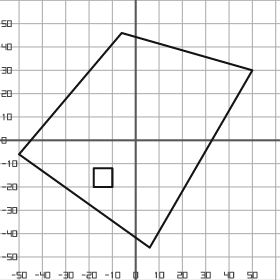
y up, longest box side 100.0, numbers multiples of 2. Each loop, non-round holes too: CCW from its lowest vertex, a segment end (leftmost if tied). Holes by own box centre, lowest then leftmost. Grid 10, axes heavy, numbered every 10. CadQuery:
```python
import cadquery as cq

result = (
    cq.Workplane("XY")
    .moveTo(6.0, -46.0)
    .lineTo(50.0, 30.0)
    .lineTo(-6.0, 46.0)
    .lineTo(-50.0, -6.0)
    .close()
    .moveTo(-18.0, -20.0)
    .lineTo(-10.0, -20.0)
    .lineTo(-10.0, -12.0)
    .lineTo(-18.0, -12.0)
    .close()
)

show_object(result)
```